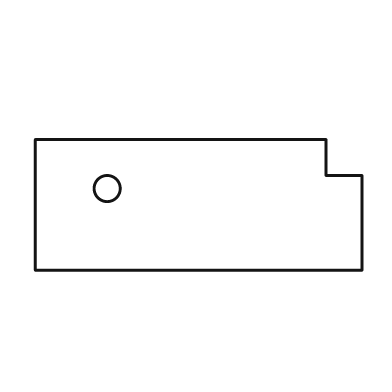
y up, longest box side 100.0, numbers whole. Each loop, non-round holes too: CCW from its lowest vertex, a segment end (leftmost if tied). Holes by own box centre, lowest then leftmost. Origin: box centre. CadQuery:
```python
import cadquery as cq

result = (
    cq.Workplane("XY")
    .moveTo(-50.0, -20.0)
    .lineTo(50.0, -20.0)
    .lineTo(50.0, 9.0)
    .lineTo(39.0, 9.0)
    .lineTo(39.0, 20.0)
    .lineTo(-50.0, 20.0)
    .close()
    .moveTo(-28.0, 5.0)
    .circle(4.0)
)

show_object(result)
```